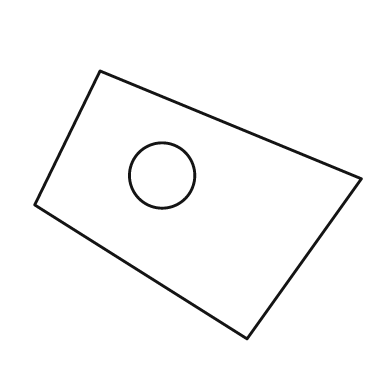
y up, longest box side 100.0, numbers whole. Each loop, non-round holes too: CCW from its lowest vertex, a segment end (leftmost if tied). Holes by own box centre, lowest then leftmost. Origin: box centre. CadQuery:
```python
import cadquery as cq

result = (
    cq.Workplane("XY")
    .moveTo(15.0, -41.0)
    .lineTo(50.0, 8.0)
    .lineTo(-30.0, 41.0)
    .lineTo(-50.0, 0.0)
    .close()
    .moveTo(-11.0, 9.0)
    .circle(10.0)
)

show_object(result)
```